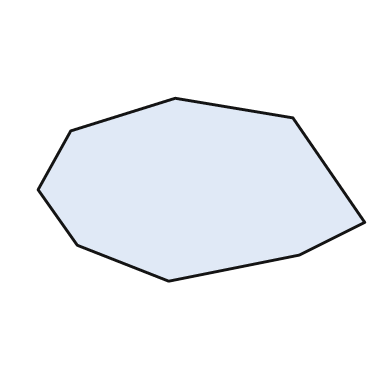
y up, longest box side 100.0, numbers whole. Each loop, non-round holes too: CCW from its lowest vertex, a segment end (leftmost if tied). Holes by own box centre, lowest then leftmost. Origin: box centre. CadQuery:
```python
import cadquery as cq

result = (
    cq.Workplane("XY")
    .moveTo(-10.0, -28.0)
    .lineTo(30.0, -20.0)
    .lineTo(50.0, -10.0)
    .lineTo(28.0, 22.0)
    .lineTo(-8.0, 28.0)
    .lineTo(-40.0, 18.0)
    .lineTo(-50.0, 0.0)
    .lineTo(-38.0, -17.0)
    .close()
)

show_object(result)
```